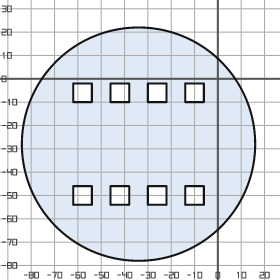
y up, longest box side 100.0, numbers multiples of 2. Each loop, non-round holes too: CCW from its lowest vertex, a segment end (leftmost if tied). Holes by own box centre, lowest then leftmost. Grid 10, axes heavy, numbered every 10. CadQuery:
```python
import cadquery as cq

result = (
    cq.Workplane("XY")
    .moveTo(-34.0, -28.0)
    .circle(50.0)
    .moveTo(-62.0, -54.0)
    .lineTo(-54.0, -54.0)
    .lineTo(-54.0, -46.0)
    .lineTo(-62.0, -46.0)
    .close()
    .moveTo(-46.0, -54.0)
    .lineTo(-38.0, -54.0)
    .lineTo(-38.0, -46.0)
    .lineTo(-46.0, -46.0)
    .close()
    .moveTo(-30.0, -54.0)
    .lineTo(-22.0, -54.0)
    .lineTo(-22.0, -46.0)
    .lineTo(-30.0, -46.0)
    .close()
    .moveTo(-14.0, -54.0)
    .lineTo(-6.0, -54.0)
    .lineTo(-6.0, -46.0)
    .lineTo(-14.0, -46.0)
    .close()
    .moveTo(-62.0, -10.0)
    .lineTo(-54.0, -10.0)
    .lineTo(-54.0, -2.0)
    .lineTo(-62.0, -2.0)
    .close()
    .moveTo(-46.0, -10.0)
    .lineTo(-38.0, -10.0)
    .lineTo(-38.0, -2.0)
    .lineTo(-46.0, -2.0)
    .close()
    .moveTo(-30.0, -10.0)
    .lineTo(-22.0, -10.0)
    .lineTo(-22.0, -2.0)
    .lineTo(-30.0, -2.0)
    .close()
    .moveTo(-14.0, -10.0)
    .lineTo(-6.0, -10.0)
    .lineTo(-6.0, -2.0)
    .lineTo(-14.0, -2.0)
    .close()
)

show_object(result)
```